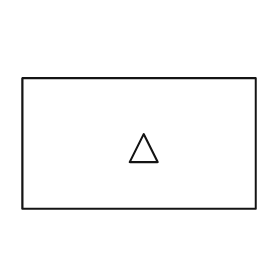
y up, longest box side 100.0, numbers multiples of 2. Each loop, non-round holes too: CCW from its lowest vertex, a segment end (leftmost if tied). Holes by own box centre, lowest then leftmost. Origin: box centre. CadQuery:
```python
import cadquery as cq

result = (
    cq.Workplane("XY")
    .moveTo(-50.0, -28.0)
    .lineTo(50.0, -28.0)
    .lineTo(50.0, 28.0)
    .lineTo(-50.0, 28.0)
    .close()
    .moveTo(-4.0, -8.0)
    .lineTo(8.0, -8.0)
    .lineTo(2.0, 4.0)
    .close()
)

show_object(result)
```